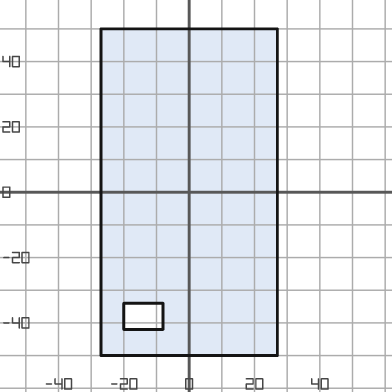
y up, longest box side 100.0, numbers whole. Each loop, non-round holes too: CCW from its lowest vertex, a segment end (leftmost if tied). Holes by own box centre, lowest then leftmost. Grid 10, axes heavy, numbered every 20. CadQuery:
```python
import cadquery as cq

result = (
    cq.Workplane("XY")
    .moveTo(-27.0, -50.0)
    .lineTo(27.0, -50.0)
    .lineTo(27.0, 50.0)
    .lineTo(-27.0, 50.0)
    .close()
    .moveTo(-20.0, -42.0)
    .lineTo(-8.0, -42.0)
    .lineTo(-8.0, -34.0)
    .lineTo(-20.0, -34.0)
    .close()
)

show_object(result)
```